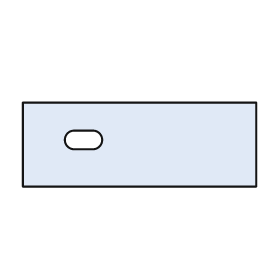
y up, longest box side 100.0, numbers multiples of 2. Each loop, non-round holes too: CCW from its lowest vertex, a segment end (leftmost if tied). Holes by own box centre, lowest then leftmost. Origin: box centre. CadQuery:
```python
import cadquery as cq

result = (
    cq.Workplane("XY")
    .moveTo(-50.0, -18.0)
    .lineTo(50.0, -18.0)
    .lineTo(50.0, 18.0)
    .lineTo(-50.0, 18.0)
    .close()
    .moveTo(-28.0, -2.0)
    .lineTo(-20.0, -2.0)
    .threePointArc((-16.0, 2.0), (-20.0, 6.0))
    .lineTo(-28.0, 6.0)
    .threePointArc((-32.0, 2.0), (-28.0, -2.0))
    .close()
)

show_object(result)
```